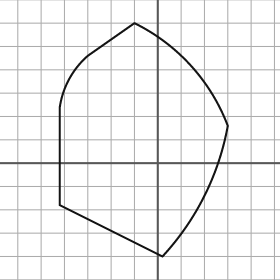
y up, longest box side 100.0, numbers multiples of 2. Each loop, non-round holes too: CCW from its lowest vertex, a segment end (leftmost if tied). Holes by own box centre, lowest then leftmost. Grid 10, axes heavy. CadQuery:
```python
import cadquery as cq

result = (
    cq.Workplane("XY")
    .moveTo(2.0, -40.0)
    .threePointArc((20.0, -14.0), (30.0, 16.0))
    .threePointArc((14.0, 42.0), (-10.0, 60.0))
    .lineTo(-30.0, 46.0)
    .threePointArc((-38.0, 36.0), (-42.0, 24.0))
    .lineTo(-42.0, -18.0)
    .close()
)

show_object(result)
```